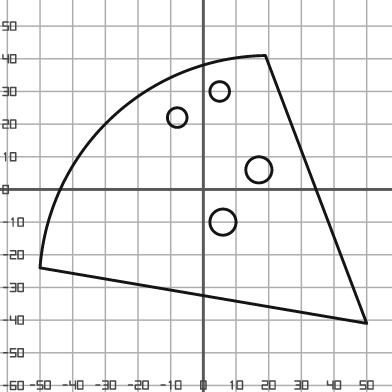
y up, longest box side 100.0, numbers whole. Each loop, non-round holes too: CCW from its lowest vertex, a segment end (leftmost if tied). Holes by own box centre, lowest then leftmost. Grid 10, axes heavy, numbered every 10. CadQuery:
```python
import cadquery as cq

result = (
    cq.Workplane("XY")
    .moveTo(50.0, -41.0)
    .lineTo(19.0, 41.0)
    .threePointArc((-28.0, 22.0), (-50.0, -24.0))
    .close()
    .moveTo(6.0, -10.0)
    .circle(4.0)
    .moveTo(17.0, 6.0)
    .circle(4.0)
    .moveTo(-8.0, 22.0)
    .circle(3.0)
    .moveTo(5.0, 30.0)
    .circle(3.0)
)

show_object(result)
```